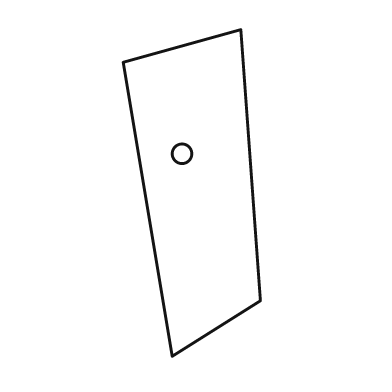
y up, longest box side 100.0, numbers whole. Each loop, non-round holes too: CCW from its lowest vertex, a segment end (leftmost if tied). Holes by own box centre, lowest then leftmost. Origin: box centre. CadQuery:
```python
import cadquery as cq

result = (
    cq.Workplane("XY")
    .moveTo(-6.0, -50.0)
    .lineTo(21.0, -33.0)
    .lineTo(15.0, 50.0)
    .lineTo(-21.0, 40.0)
    .close()
    .moveTo(-3.0, 12.0)
    .circle(3.0)
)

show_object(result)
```